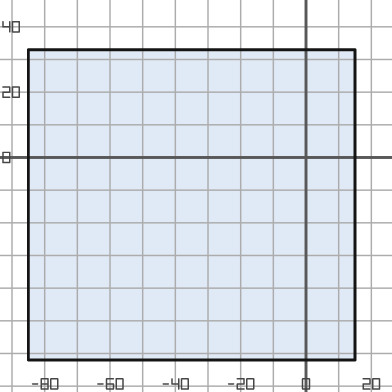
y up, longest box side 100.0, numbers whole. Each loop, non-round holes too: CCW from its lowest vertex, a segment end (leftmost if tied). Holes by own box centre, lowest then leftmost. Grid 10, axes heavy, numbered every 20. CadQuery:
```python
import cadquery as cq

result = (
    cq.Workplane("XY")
    .moveTo(-85.0, -62.0)
    .lineTo(15.0, -62.0)
    .lineTo(15.0, 33.0)
    .lineTo(-85.0, 33.0)
    .close()
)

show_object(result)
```